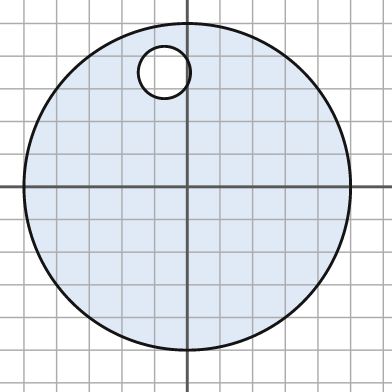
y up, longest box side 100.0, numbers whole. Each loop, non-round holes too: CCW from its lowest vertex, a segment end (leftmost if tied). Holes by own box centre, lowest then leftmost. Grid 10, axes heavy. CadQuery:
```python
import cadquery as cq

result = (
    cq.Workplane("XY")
    .moveTo(0.0, 0.0)
    .circle(50.0)
    .moveTo(-7.0, 35.0)
    .circle(8.0)
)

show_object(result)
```